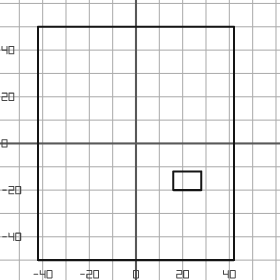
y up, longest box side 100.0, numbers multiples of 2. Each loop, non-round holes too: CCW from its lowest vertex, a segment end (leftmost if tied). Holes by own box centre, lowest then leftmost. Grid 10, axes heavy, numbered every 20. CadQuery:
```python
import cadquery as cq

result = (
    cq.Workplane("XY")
    .moveTo(-42.0, -50.0)
    .lineTo(42.0, -50.0)
    .lineTo(42.0, 50.0)
    .lineTo(-42.0, 50.0)
    .close()
    .moveTo(16.0, -20.0)
    .lineTo(28.0, -20.0)
    .lineTo(28.0, -12.0)
    .lineTo(16.0, -12.0)
    .close()
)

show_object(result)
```